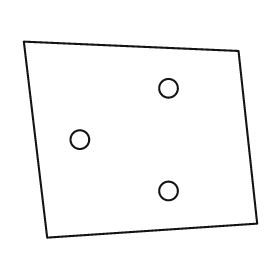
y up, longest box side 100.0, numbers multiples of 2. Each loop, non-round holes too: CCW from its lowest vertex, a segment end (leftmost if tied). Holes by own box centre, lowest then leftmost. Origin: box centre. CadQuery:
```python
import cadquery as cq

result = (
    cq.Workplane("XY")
    .moveTo(-40.0, -42.0)
    .lineTo(50.0, -36.0)
    .lineTo(42.0, 38.0)
    .lineTo(-50.0, 42.0)
    .close()
    .moveTo(12.0, -22.0)
    .circle(4.0)
    .moveTo(-26.0, 0.0)
    .circle(4.0)
    .moveTo(12.0, 22.0)
    .circle(4.0)
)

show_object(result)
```